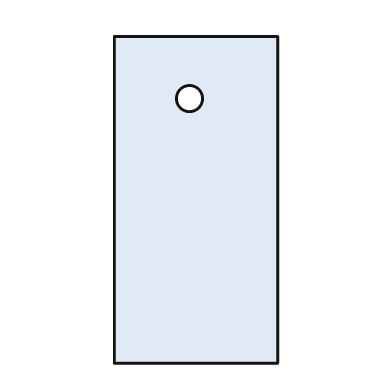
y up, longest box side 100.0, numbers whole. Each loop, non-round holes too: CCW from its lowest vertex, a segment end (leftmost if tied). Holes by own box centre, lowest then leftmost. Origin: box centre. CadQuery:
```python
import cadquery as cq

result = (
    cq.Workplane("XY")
    .moveTo(-25.0, -50.0)
    .lineTo(25.0, -50.0)
    .lineTo(25.0, 50.0)
    .lineTo(-25.0, 50.0)
    .close()
    .moveTo(-2.0, 31.0)
    .circle(4.0)
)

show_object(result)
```